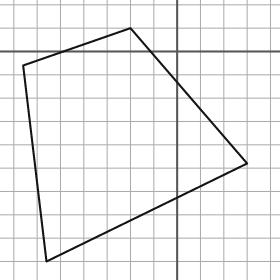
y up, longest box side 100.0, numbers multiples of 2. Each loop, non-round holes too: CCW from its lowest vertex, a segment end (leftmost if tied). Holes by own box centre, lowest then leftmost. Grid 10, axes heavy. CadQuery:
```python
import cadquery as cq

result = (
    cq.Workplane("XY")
    .moveTo(-56.0, -90.0)
    .lineTo(30.0, -48.0)
    .lineTo(-20.0, 10.0)
    .lineTo(-66.0, -6.0)
    .close()
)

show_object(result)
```